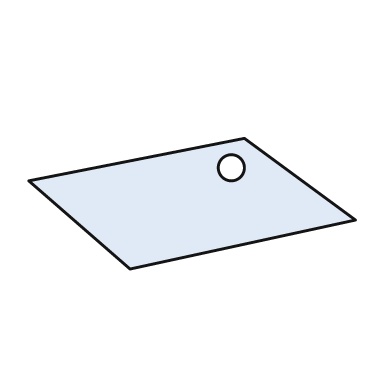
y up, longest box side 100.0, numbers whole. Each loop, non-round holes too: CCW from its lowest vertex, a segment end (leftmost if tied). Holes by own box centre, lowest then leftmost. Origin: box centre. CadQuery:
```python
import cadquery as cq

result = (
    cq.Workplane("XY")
    .moveTo(-19.0, -20.0)
    .lineTo(50.0, -5.0)
    .lineTo(16.0, 20.0)
    .lineTo(-50.0, 7.0)
    .close()
    .moveTo(12.0, 11.0)
    .circle(4.0)
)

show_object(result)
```